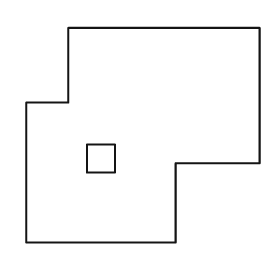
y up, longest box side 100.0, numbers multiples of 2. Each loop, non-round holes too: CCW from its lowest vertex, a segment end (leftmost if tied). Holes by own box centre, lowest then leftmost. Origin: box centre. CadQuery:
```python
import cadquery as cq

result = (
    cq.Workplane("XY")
    .moveTo(-50.0, -46.0)
    .lineTo(14.0, -46.0)
    .lineTo(14.0, -12.0)
    .lineTo(50.0, -12.0)
    .lineTo(50.0, 46.0)
    .lineTo(-32.0, 46.0)
    .lineTo(-32.0, 14.0)
    .lineTo(-50.0, 14.0)
    .close()
    .moveTo(-24.0, -16.0)
    .lineTo(-12.0, -16.0)
    .lineTo(-12.0, -4.0)
    .lineTo(-24.0, -4.0)
    .close()
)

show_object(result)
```